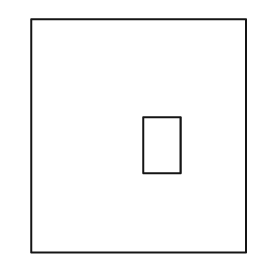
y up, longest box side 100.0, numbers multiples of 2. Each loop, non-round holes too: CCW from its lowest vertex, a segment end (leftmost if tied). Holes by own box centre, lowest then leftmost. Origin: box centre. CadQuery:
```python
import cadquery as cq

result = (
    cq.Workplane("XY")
    .moveTo(-46.0, -50.0)
    .lineTo(46.0, -50.0)
    .lineTo(46.0, 50.0)
    .lineTo(-46.0, 50.0)
    .close()
    .moveTo(2.0, -16.0)
    .lineTo(18.0, -16.0)
    .lineTo(18.0, 8.0)
    .lineTo(2.0, 8.0)
    .close()
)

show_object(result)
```